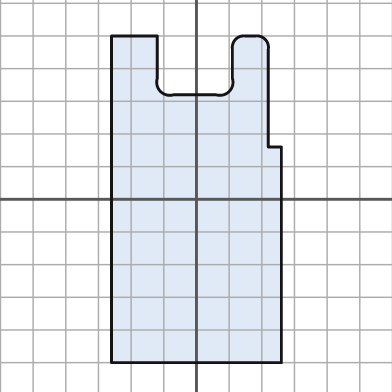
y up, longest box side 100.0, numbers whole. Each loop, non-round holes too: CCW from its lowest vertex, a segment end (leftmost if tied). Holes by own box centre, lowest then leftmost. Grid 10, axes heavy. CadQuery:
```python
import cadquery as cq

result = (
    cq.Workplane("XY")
    .moveTo(-26.0, -50.0)
    .lineTo(26.0, -50.0)
    .lineTo(26.0, 16.0)
    .lineTo(22.0, 16.0)
    .lineTo(22.0, 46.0)
    .threePointArc((21.0, 49.0), (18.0, 50.0))
    .lineTo(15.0, 50.0)
    .threePointArc((12.0, 49.0), (11.0, 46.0))
    .lineTo(11.0, 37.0)
    .threePointArc((10.0, 33.0), (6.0, 32.0))
    .lineTo(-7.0, 32.0)
    .threePointArc((-11.0, 33.0), (-12.0, 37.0))
    .lineTo(-12.0, 50.0)
    .lineTo(-26.0, 50.0)
    .close()
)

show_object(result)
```